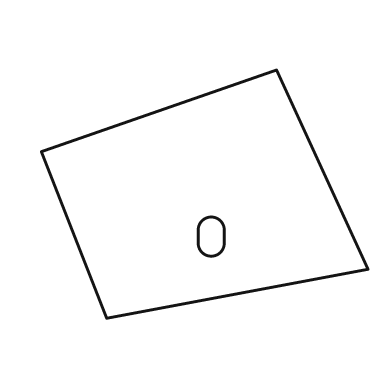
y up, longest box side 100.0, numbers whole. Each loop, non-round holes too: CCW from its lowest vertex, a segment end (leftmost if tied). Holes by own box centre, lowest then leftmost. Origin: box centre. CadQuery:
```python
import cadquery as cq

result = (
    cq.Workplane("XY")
    .moveTo(-30.0, -38.0)
    .lineTo(50.0, -23.0)
    .lineTo(22.0, 38.0)
    .lineTo(-50.0, 13.0)
    .close()
    .moveTo(-2.0, -15.0)
    .threePointArc((2.0, -19.0), (6.0, -15.0))
    .lineTo(6.0, -11.0)
    .threePointArc((2.0, -7.0), (-2.0, -11.0))
    .close()
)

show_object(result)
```